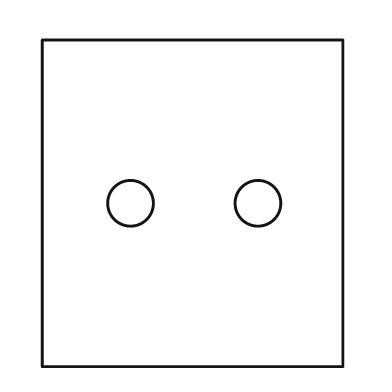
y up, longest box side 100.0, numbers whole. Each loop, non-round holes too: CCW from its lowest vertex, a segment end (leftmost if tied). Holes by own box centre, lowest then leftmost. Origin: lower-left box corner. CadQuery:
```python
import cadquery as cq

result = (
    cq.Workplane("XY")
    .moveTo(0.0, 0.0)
    .lineTo(92.0, 0.0)
    .lineTo(92.0, 100.0)
    .lineTo(0.0, 100.0)
    .close()
    .moveTo(27.0, 50.0)
    .circle(7.0)
    .moveTo(66.0, 50.0)
    .circle(7.0)
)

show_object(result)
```